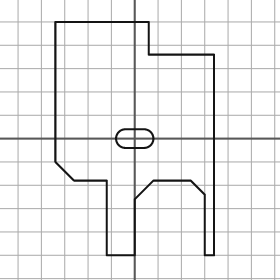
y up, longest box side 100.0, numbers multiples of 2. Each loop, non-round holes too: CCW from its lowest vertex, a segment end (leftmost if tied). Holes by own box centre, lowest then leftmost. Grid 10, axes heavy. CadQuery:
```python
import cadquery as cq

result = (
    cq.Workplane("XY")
    .moveTo(-12.0, -50.0)
    .lineTo(0.0, -50.0)
    .lineTo(0.0, -26.0)
    .lineTo(8.0, -18.0)
    .lineTo(24.0, -18.0)
    .lineTo(30.0, -24.0)
    .lineTo(30.0, -50.0)
    .lineTo(34.0, -50.0)
    .lineTo(34.0, 36.0)
    .lineTo(6.0, 36.0)
    .lineTo(6.0, 50.0)
    .lineTo(-34.0, 50.0)
    .lineTo(-34.0, -10.0)
    .lineTo(-26.0, -18.0)
    .lineTo(-12.0, -18.0)
    .close()
    .moveTo(-4.0, -4.0)
    .lineTo(4.0, -4.0)
    .threePointArc((8.0, 0.0), (4.0, 4.0))
    .lineTo(-4.0, 4.0)
    .threePointArc((-8.0, 0.0), (-4.0, -4.0))
    .close()
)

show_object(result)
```